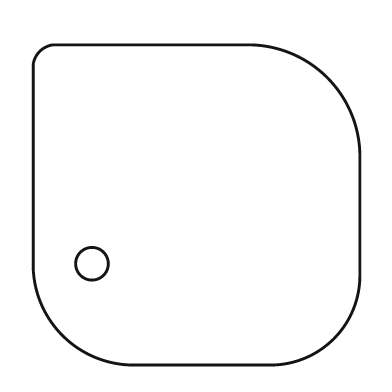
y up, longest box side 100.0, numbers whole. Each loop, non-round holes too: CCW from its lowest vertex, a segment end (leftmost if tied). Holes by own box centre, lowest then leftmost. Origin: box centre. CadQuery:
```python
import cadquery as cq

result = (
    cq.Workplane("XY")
    .moveTo(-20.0, -49.0)
    .lineTo(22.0, -49.0)
    .threePointArc((42.0, -41.0), (50.0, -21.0))
    .lineTo(50.0, 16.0)
    .threePointArc((40.0, 39.0), (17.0, 49.0))
    .lineTo(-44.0, 49.0)
    .threePointArc((-48.0, 47.0), (-50.0, 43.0))
    .lineTo(-50.0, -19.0)
    .threePointArc((-41.0, -40.0), (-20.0, -49.0))
    .close()
    .moveTo(-32.0, -18.0)
    .circle(5.0)
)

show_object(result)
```